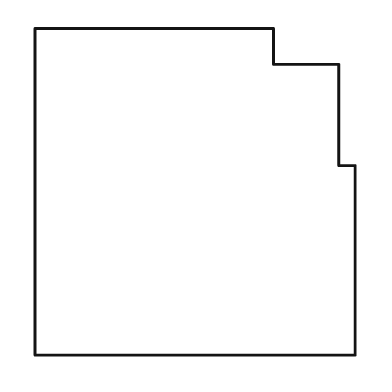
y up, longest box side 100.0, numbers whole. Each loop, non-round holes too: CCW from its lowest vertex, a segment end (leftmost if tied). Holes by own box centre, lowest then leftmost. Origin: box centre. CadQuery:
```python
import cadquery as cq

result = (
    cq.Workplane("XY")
    .moveTo(-49.0, -50.0)
    .lineTo(49.0, -50.0)
    .lineTo(49.0, 8.0)
    .lineTo(44.0, 8.0)
    .lineTo(44.0, 39.0)
    .lineTo(24.0, 39.0)
    .lineTo(24.0, 50.0)
    .lineTo(-49.0, 50.0)
    .close()
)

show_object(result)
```